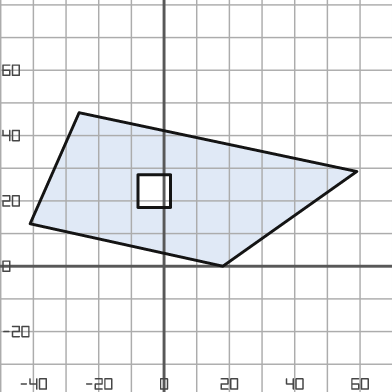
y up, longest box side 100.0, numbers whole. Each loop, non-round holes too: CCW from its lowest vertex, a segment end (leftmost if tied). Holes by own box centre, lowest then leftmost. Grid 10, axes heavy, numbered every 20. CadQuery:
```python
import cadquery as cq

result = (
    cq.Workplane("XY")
    .moveTo(18.0, 0.0)
    .lineTo(59.0, 29.0)
    .lineTo(-26.0, 47.0)
    .lineTo(-41.0, 13.0)
    .close()
    .moveTo(-8.0, 18.0)
    .lineTo(2.0, 18.0)
    .lineTo(2.0, 28.0)
    .lineTo(-8.0, 28.0)
    .close()
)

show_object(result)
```